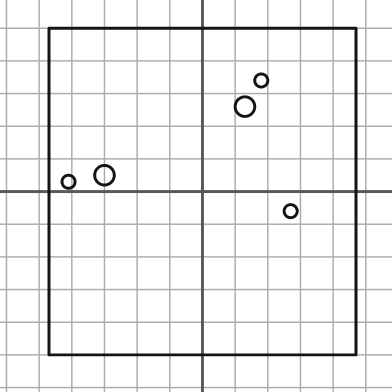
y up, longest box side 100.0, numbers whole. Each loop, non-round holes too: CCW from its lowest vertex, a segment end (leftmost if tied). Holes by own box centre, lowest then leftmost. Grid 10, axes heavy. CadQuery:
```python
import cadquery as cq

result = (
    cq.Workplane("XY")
    .moveTo(-47.0, -50.0)
    .lineTo(47.0, -50.0)
    .lineTo(47.0, 50.0)
    .lineTo(-47.0, 50.0)
    .close()
    .moveTo(27.0, -6.0)
    .circle(2.0)
    .moveTo(-41.0, 3.0)
    .circle(2.0)
    .moveTo(-30.0, 5.0)
    .circle(3.0)
    .moveTo(13.0, 26.0)
    .circle(3.0)
    .moveTo(18.0, 34.0)
    .circle(2.0)
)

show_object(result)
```